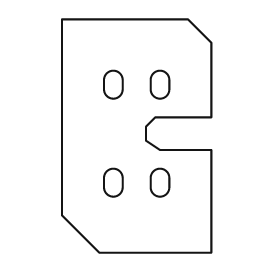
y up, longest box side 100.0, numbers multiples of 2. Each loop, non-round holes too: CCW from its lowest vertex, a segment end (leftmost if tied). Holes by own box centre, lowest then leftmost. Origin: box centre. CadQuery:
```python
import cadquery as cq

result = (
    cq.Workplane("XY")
    .moveTo(-16.0, -50.0)
    .lineTo(32.0, -50.0)
    .lineTo(32.0, -6.0)
    .lineTo(10.0, -6.0)
    .lineTo(4.0, -2.0)
    .lineTo(4.0, 4.0)
    .lineTo(8.0, 8.0)
    .lineTo(32.0, 8.0)
    .lineTo(32.0, 40.0)
    .lineTo(22.0, 50.0)
    .lineTo(-32.0, 50.0)
    .lineTo(-32.0, -34.0)
    .close()
    .moveTo(-14.0, -22.0)
    .threePointArc((-10.0, -26.0), (-6.0, -22.0))
    .lineTo(-6.0, -18.0)
    .threePointArc((-10.0, -14.0), (-14.0, -18.0))
    .close()
    .moveTo(6.0, -22.0)
    .threePointArc((10.0, -26.0), (14.0, -22.0))
    .lineTo(14.0, -18.0)
    .threePointArc((10.0, -14.0), (6.0, -18.0))
    .close()
    .moveTo(-14.0, 20.0)
    .threePointArc((-10.0, 16.0), (-6.0, 20.0))
    .lineTo(-6.0, 24.0)
    .threePointArc((-10.0, 28.0), (-14.0, 24.0))
    .close()
    .moveTo(6.0, 20.0)
    .threePointArc((10.0, 16.0), (14.0, 20.0))
    .lineTo(14.0, 24.0)
    .threePointArc((10.0, 28.0), (6.0, 24.0))
    .close()
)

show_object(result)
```